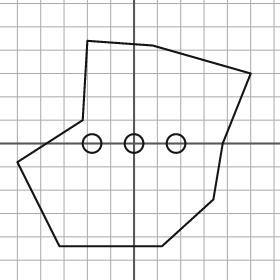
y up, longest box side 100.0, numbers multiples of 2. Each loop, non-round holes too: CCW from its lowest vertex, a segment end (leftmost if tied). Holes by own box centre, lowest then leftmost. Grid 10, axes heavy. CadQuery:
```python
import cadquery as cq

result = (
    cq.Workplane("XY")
    .moveTo(-32.0, -44.0)
    .lineTo(12.0, -44.0)
    .lineTo(34.0, -24.0)
    .lineTo(38.0, 0.0)
    .lineTo(50.0, 30.0)
    .lineTo(8.0, 42.0)
    .lineTo(-20.0, 44.0)
    .lineTo(-22.0, 10.0)
    .lineTo(-50.0, -8.0)
    .close()
    .moveTo(-18.0, 0.0)
    .circle(4.0)
    .moveTo(0.0, 0.0)
    .circle(4.0)
    .moveTo(18.0, 0.0)
    .circle(4.0)
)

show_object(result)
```